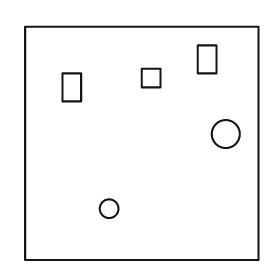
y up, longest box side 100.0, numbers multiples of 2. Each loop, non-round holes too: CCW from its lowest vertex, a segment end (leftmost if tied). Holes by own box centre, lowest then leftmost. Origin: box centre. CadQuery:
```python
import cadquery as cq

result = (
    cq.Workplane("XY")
    .moveTo(-50.0, -50.0)
    .lineTo(50.0, -50.0)
    .lineTo(50.0, 50.0)
    .lineTo(-50.0, 50.0)
    .close()
    .moveTo(-14.0, -28.0)
    .circle(4.0)
    .moveTo(36.0, 4.0)
    .circle(6.0)
    .moveTo(-34.0, 18.0)
    .lineTo(-26.0, 18.0)
    .lineTo(-26.0, 30.0)
    .lineTo(-34.0, 30.0)
    .close()
    .moveTo(0.0, 24.0)
    .lineTo(8.0, 24.0)
    .lineTo(8.0, 32.0)
    .lineTo(0.0, 32.0)
    .close()
    .moveTo(24.0, 30.0)
    .lineTo(32.0, 30.0)
    .lineTo(32.0, 42.0)
    .lineTo(24.0, 42.0)
    .close()
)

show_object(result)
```